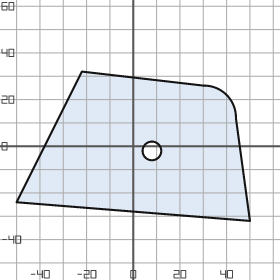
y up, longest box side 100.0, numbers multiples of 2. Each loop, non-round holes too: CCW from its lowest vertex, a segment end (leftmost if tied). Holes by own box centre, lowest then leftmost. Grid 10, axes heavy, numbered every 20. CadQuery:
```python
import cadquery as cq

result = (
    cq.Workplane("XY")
    .moveTo(50.0, -32.0)
    .lineTo(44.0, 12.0)
    .threePointArc((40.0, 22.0), (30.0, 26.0))
    .lineTo(-22.0, 32.0)
    .lineTo(-50.0, -24.0)
    .close()
    .moveTo(8.0, -2.0)
    .circle(4.0)
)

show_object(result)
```